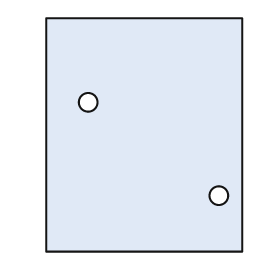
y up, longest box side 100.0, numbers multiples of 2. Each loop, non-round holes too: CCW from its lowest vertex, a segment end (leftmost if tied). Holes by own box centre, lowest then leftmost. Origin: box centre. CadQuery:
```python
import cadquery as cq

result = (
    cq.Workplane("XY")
    .moveTo(-42.0, -50.0)
    .lineTo(42.0, -50.0)
    .lineTo(42.0, 50.0)
    .lineTo(-42.0, 50.0)
    .close()
    .moveTo(32.0, -26.0)
    .circle(4.0)
    .moveTo(-24.0, 14.0)
    .circle(4.0)
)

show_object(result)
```